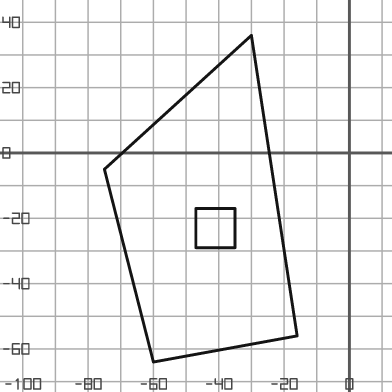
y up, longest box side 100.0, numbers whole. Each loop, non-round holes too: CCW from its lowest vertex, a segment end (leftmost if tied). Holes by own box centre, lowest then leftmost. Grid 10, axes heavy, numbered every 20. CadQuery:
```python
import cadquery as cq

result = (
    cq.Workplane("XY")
    .moveTo(-60.0, -64.0)
    .lineTo(-16.0, -56.0)
    .lineTo(-30.0, 36.0)
    .lineTo(-75.0, -5.0)
    .close()
    .moveTo(-47.0, -29.0)
    .lineTo(-35.0, -29.0)
    .lineTo(-35.0, -17.0)
    .lineTo(-47.0, -17.0)
    .close()
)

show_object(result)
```